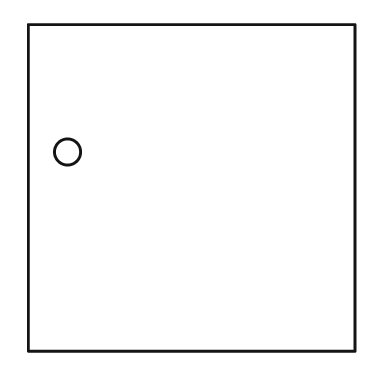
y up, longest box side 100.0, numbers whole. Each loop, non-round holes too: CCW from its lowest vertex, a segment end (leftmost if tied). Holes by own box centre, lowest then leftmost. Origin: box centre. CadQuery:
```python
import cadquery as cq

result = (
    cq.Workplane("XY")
    .moveTo(-50.0, -50.0)
    .lineTo(50.0, -50.0)
    .lineTo(50.0, 50.0)
    .lineTo(-50.0, 50.0)
    .close()
    .moveTo(-38.0, 11.0)
    .circle(4.0)
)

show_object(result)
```